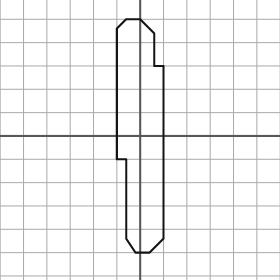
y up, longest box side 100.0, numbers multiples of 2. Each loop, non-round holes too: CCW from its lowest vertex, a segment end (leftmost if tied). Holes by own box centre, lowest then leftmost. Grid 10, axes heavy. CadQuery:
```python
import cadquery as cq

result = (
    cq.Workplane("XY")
    .moveTo(-2.0, -50.0)
    .lineTo(4.0, -50.0)
    .lineTo(10.0, -44.0)
    .lineTo(10.0, 30.0)
    .lineTo(6.0, 30.0)
    .lineTo(6.0, 44.0)
    .lineTo(0.0, 50.0)
    .lineTo(-6.0, 50.0)
    .lineTo(-10.0, 46.0)
    .lineTo(-10.0, -10.0)
    .lineTo(-6.0, -10.0)
    .lineTo(-6.0, -44.0)
    .close()
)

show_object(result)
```